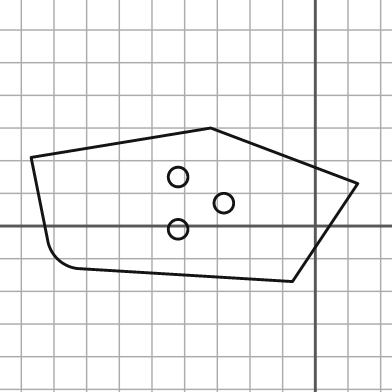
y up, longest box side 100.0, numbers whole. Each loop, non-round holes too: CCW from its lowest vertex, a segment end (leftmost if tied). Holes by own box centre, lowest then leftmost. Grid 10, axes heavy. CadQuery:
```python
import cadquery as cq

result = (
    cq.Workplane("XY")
    .moveTo(-7.0, -17.0)
    .lineTo(13.0, 13.0)
    .lineTo(-32.0, 30.0)
    .lineTo(-87.0, 21.0)
    .lineTo(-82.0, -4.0)
    .threePointArc((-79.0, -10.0), (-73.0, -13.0))
    .close()
    .moveTo(-42.0, -1.0)
    .circle(3.0)
    .moveTo(-28.0, 7.0)
    .circle(3.0)
    .moveTo(-42.0, 15.0)
    .circle(3.0)
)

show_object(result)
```